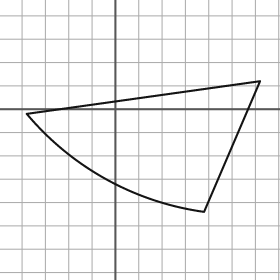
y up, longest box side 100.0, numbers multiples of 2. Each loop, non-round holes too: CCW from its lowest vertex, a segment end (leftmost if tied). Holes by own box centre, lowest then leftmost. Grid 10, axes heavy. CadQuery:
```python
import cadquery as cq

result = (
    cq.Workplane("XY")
    .moveTo(38.0, -44.0)
    .lineTo(62.0, 12.0)
    .lineTo(-38.0, -2.0)
    .threePointArc((-4.0, -30.0), (38.0, -44.0))
    .close()
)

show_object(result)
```